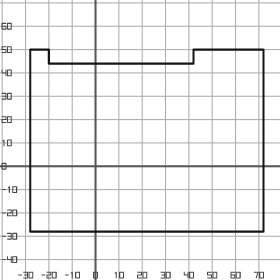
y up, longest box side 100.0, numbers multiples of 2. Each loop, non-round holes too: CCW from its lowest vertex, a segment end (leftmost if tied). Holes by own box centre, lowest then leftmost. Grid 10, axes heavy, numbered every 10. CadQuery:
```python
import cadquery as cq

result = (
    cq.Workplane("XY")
    .moveTo(-28.0, -28.0)
    .lineTo(72.0, -28.0)
    .lineTo(72.0, 50.0)
    .lineTo(42.0, 50.0)
    .lineTo(42.0, 44.0)
    .lineTo(-20.0, 44.0)
    .lineTo(-20.0, 50.0)
    .lineTo(-28.0, 50.0)
    .close()
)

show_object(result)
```